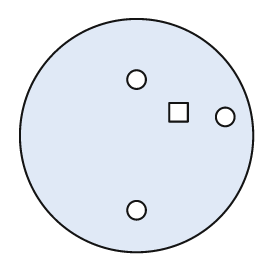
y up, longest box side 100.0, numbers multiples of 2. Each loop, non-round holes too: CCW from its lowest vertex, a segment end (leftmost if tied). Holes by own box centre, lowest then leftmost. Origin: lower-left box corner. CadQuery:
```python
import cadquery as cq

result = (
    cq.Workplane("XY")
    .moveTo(50.0, 50.0)
    .circle(50.0)
    .moveTo(50.0, 18.0)
    .circle(4.0)
    .moveTo(88.0, 58.0)
    .circle(4.0)
    .moveTo(64.0, 56.0)
    .lineTo(72.0, 56.0)
    .lineTo(72.0, 64.0)
    .lineTo(64.0, 64.0)
    .close()
    .moveTo(50.0, 74.0)
    .circle(4.0)
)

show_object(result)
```